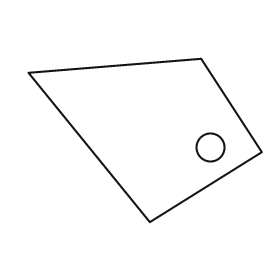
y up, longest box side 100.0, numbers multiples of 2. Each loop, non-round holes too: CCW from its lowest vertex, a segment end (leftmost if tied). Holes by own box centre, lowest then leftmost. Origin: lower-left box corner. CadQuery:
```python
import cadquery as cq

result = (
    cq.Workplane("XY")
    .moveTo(52.0, 0.0)
    .lineTo(100.0, 30.0)
    .lineTo(74.0, 70.0)
    .lineTo(0.0, 64.0)
    .close()
    .moveTo(78.0, 32.0)
    .circle(6.0)
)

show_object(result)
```